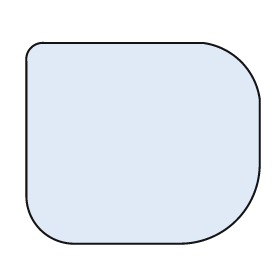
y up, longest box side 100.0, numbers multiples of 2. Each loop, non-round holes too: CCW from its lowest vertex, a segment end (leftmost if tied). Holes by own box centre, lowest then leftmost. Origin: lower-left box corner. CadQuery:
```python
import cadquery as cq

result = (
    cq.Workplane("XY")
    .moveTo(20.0, 0.0)
    .lineTo(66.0, 0.0)
    .threePointArc((90.0, 10.0), (100.0, 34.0))
    .lineTo(100.0, 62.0)
    .threePointArc((92.0, 78.0), (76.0, 86.0))
    .lineTo(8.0, 86.0)
    .threePointArc((2.0, 84.0), (0.0, 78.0))
    .lineTo(0.0, 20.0)
    .threePointArc((6.0, 6.0), (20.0, 0.0))
    .close()
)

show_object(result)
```